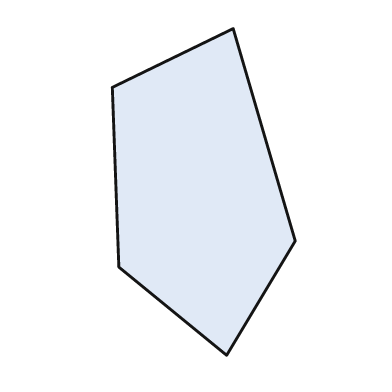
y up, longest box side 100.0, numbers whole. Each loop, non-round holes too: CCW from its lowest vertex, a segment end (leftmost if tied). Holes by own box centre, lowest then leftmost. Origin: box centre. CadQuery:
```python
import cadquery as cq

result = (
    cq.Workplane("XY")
    .moveTo(7.0, -50.0)
    .lineTo(28.0, -15.0)
    .lineTo(9.0, 50.0)
    .lineTo(-28.0, 32.0)
    .lineTo(-26.0, -23.0)
    .close()
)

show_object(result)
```